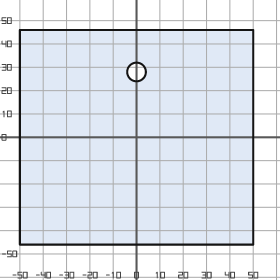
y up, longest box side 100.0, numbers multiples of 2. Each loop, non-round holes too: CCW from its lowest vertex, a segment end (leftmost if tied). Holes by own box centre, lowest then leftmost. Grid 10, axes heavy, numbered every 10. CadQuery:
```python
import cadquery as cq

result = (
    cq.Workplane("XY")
    .moveTo(-50.0, -46.0)
    .lineTo(50.0, -46.0)
    .lineTo(50.0, 46.0)
    .lineTo(-50.0, 46.0)
    .close()
    .moveTo(0.0, 28.0)
    .circle(4.0)
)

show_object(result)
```